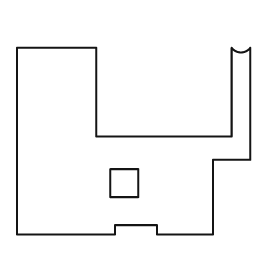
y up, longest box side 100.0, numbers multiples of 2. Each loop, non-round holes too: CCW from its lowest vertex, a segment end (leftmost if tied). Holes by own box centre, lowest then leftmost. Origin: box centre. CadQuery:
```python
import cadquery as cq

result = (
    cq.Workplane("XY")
    .moveTo(-50.0, -40.0)
    .lineTo(-8.0, -40.0)
    .lineTo(-8.0, -36.0)
    .lineTo(10.0, -36.0)
    .lineTo(10.0, -40.0)
    .lineTo(34.0, -40.0)
    .lineTo(34.0, -8.0)
    .lineTo(50.0, -8.0)
    .lineTo(50.0, 40.0)
    .threePointArc((46.0, 38.0), (42.0, 40.0))
    .lineTo(42.0, 2.0)
    .lineTo(-16.0, 2.0)
    .lineTo(-16.0, 40.0)
    .lineTo(-50.0, 40.0)
    .close()
    .moveTo(-10.0, -24.0)
    .lineTo(2.0, -24.0)
    .lineTo(2.0, -12.0)
    .lineTo(-10.0, -12.0)
    .close()
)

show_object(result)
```